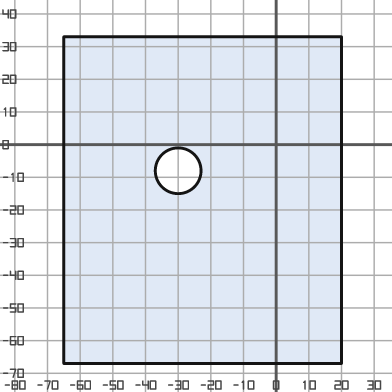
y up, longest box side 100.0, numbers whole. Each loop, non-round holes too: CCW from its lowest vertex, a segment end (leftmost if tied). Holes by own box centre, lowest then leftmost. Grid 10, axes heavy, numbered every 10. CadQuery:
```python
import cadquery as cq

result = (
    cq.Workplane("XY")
    .moveTo(-65.0, -67.0)
    .lineTo(20.0, -67.0)
    .lineTo(20.0, 33.0)
    .lineTo(-65.0, 33.0)
    .close()
    .moveTo(-30.0, -8.0)
    .circle(7.0)
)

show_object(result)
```